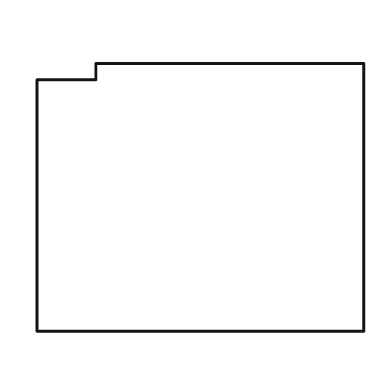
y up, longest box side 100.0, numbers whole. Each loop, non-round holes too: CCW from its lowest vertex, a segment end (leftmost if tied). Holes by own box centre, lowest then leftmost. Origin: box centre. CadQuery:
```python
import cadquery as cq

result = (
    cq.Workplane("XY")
    .moveTo(-50.0, -41.0)
    .lineTo(50.0, -41.0)
    .lineTo(50.0, 41.0)
    .lineTo(-32.0, 41.0)
    .lineTo(-32.0, 36.0)
    .lineTo(-50.0, 36.0)
    .close()
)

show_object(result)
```